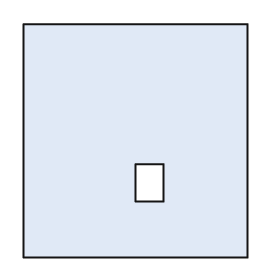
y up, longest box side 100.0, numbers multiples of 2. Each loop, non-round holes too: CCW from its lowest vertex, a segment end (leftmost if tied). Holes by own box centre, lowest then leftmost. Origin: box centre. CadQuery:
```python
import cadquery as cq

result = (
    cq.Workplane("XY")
    .moveTo(-48.0, -50.0)
    .lineTo(48.0, -50.0)
    .lineTo(48.0, 50.0)
    .lineTo(-48.0, 50.0)
    .close()
    .moveTo(0.0, -26.0)
    .lineTo(12.0, -26.0)
    .lineTo(12.0, -10.0)
    .lineTo(0.0, -10.0)
    .close()
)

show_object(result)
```